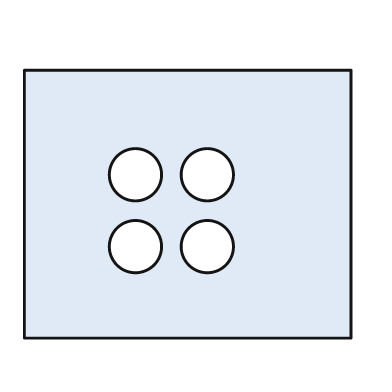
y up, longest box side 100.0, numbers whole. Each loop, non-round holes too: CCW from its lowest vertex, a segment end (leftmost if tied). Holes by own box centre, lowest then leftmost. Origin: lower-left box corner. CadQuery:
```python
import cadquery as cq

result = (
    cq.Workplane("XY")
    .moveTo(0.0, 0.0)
    .lineTo(100.0, 0.0)
    .lineTo(100.0, 82.0)
    .lineTo(0.0, 82.0)
    .close()
    .moveTo(34.0, 28.0)
    .circle(8.0)
    .moveTo(56.0, 28.0)
    .circle(8.0)
    .moveTo(34.0, 50.0)
    .circle(8.0)
    .moveTo(56.0, 50.0)
    .circle(8.0)
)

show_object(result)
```